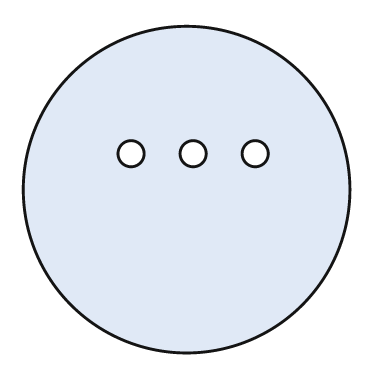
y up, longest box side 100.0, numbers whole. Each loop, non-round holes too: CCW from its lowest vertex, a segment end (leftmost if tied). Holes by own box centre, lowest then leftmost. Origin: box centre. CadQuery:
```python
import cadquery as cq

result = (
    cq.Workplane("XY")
    .moveTo(0.0, 0.0)
    .circle(50.0)
    .moveTo(-17.0, 11.0)
    .circle(4.0)
    .moveTo(2.0, 11.0)
    .circle(4.0)
    .moveTo(21.0, 11.0)
    .circle(4.0)
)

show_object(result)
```